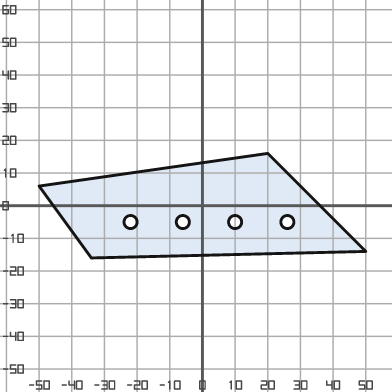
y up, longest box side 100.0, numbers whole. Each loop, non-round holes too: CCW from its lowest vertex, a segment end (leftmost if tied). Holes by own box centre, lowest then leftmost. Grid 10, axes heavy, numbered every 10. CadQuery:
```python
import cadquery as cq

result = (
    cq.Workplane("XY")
    .moveTo(-34.0, -16.0)
    .lineTo(50.0, -14.0)
    .lineTo(20.0, 16.0)
    .lineTo(-50.0, 6.0)
    .close()
    .moveTo(-22.0, -5.0)
    .circle(2.0)
    .moveTo(-6.0, -5.0)
    .circle(2.0)
    .moveTo(10.0, -5.0)
    .circle(2.0)
    .moveTo(26.0, -5.0)
    .circle(2.0)
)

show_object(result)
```